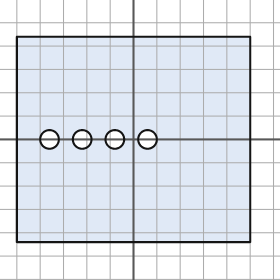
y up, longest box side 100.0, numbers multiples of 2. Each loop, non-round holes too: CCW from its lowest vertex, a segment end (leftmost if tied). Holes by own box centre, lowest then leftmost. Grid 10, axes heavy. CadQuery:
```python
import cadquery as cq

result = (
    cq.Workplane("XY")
    .moveTo(-50.0, -44.0)
    .lineTo(50.0, -44.0)
    .lineTo(50.0, 44.0)
    .lineTo(-50.0, 44.0)
    .close()
    .moveTo(-36.0, 0.0)
    .circle(4.0)
    .moveTo(-22.0, 0.0)
    .circle(4.0)
    .moveTo(-8.0, 0.0)
    .circle(4.0)
    .moveTo(6.0, 0.0)
    .circle(4.0)
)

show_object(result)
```